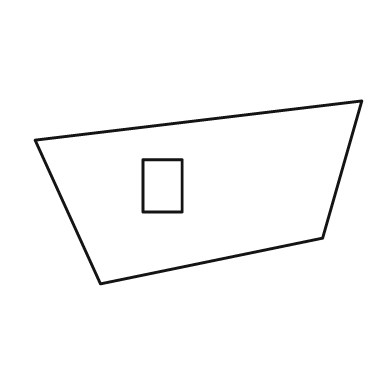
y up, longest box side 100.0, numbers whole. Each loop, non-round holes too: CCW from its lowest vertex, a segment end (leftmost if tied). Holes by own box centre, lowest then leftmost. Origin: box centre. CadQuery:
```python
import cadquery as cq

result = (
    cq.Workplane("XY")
    .moveTo(-30.0, -28.0)
    .lineTo(38.0, -14.0)
    .lineTo(50.0, 28.0)
    .lineTo(-50.0, 16.0)
    .close()
    .moveTo(-17.0, -6.0)
    .lineTo(-5.0, -6.0)
    .lineTo(-5.0, 10.0)
    .lineTo(-17.0, 10.0)
    .close()
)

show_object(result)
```